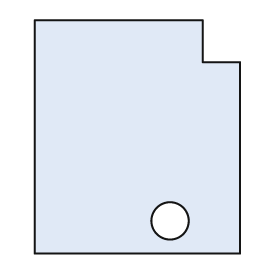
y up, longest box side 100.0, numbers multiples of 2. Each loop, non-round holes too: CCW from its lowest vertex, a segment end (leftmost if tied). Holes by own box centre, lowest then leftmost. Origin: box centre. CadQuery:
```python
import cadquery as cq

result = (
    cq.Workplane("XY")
    .moveTo(-44.0, -50.0)
    .lineTo(44.0, -50.0)
    .lineTo(44.0, 32.0)
    .lineTo(28.0, 32.0)
    .lineTo(28.0, 50.0)
    .lineTo(-44.0, 50.0)
    .close()
    .moveTo(14.0, -36.0)
    .circle(8.0)
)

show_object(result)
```